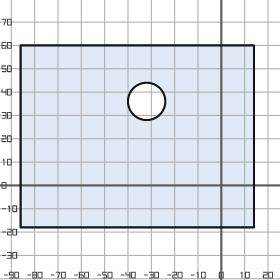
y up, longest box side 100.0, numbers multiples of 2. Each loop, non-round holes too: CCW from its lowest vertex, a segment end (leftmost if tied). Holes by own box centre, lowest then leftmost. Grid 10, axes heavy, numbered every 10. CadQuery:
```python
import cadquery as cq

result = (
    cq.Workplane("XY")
    .moveTo(-86.0, -18.0)
    .lineTo(14.0, -18.0)
    .lineTo(14.0, 60.0)
    .lineTo(-86.0, 60.0)
    .close()
    .moveTo(-32.0, 36.0)
    .circle(8.0)
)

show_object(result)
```